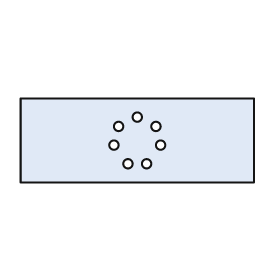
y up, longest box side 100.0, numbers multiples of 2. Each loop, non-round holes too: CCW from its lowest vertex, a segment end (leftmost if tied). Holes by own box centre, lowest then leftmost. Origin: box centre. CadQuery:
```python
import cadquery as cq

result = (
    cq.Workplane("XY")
    .moveTo(-50.0, -18.0)
    .lineTo(50.0, -18.0)
    .lineTo(50.0, 18.0)
    .lineTo(-50.0, 18.0)
    .close()
    .moveTo(-4.0, -10.0)
    .circle(2.0)
    .moveTo(4.0, -10.0)
    .circle(2.0)
    .moveTo(-10.0, -2.0)
    .circle(2.0)
    .moveTo(10.0, -2.0)
    .circle(2.0)
    .moveTo(-8.0, 6.0)
    .circle(2.0)
    .moveTo(8.0, 6.0)
    .circle(2.0)
    .moveTo(0.0, 10.0)
    .circle(2.0)
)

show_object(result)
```